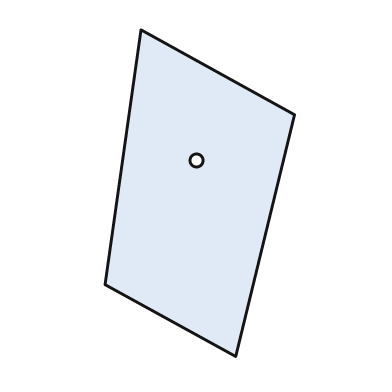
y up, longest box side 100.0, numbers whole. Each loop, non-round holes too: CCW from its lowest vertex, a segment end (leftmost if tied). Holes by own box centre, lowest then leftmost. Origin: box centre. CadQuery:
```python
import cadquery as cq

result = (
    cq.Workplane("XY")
    .moveTo(11.0, -50.0)
    .lineTo(29.0, 24.0)
    .lineTo(-18.0, 50.0)
    .lineTo(-29.0, -28.0)
    .close()
    .moveTo(-1.0, 10.0)
    .circle(2.0)
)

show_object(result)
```